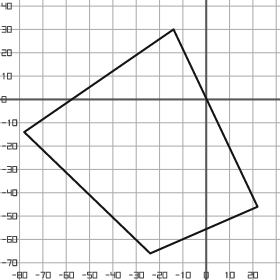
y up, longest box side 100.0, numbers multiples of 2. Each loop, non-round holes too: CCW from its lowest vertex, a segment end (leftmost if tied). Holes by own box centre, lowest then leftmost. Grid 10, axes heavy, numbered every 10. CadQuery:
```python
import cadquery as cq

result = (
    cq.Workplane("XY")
    .moveTo(-24.0, -66.0)
    .lineTo(22.0, -46.0)
    .lineTo(-14.0, 30.0)
    .lineTo(-78.0, -14.0)
    .close()
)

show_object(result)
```